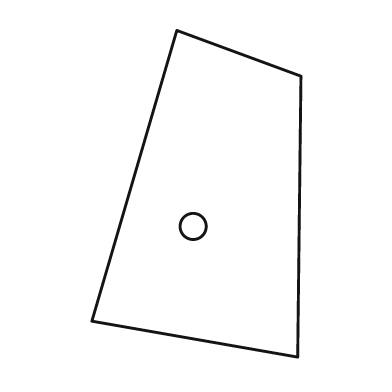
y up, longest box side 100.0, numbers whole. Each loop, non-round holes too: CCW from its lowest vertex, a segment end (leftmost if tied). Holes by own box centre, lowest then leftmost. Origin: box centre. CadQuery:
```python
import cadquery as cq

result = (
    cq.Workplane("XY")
    .moveTo(31.0, -50.0)
    .lineTo(32.0, 36.0)
    .lineTo(-6.0, 50.0)
    .lineTo(-32.0, -39.0)
    .close()
    .moveTo(-1.0, -10.0)
    .circle(4.0)
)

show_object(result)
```